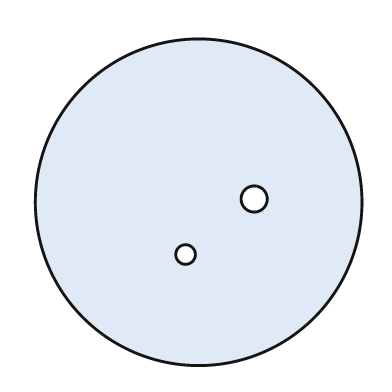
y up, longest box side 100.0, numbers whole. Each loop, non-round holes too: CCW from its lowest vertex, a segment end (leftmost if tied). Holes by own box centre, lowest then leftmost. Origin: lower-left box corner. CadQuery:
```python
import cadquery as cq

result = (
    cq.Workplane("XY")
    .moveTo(50.0, 50.0)
    .circle(50.0)
    .moveTo(46.0, 34.0)
    .circle(3.0)
    .moveTo(67.0, 51.0)
    .circle(4.0)
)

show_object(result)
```